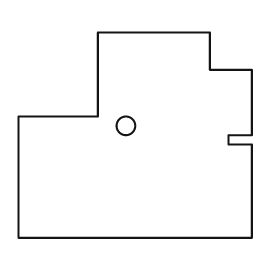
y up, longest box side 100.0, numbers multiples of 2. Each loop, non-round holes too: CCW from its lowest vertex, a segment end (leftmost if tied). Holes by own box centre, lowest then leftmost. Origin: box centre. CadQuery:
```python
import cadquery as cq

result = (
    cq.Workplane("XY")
    .moveTo(-50.0, -44.0)
    .lineTo(50.0, -44.0)
    .lineTo(50.0, -4.0)
    .lineTo(40.0, -4.0)
    .lineTo(40.0, 0.0)
    .lineTo(50.0, 0.0)
    .lineTo(50.0, 28.0)
    .lineTo(32.0, 28.0)
    .lineTo(32.0, 44.0)
    .lineTo(-16.0, 44.0)
    .lineTo(-16.0, 8.0)
    .lineTo(-50.0, 8.0)
    .close()
    .moveTo(-4.0, 4.0)
    .circle(4.0)
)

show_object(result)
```